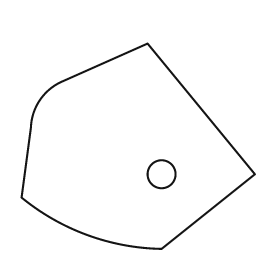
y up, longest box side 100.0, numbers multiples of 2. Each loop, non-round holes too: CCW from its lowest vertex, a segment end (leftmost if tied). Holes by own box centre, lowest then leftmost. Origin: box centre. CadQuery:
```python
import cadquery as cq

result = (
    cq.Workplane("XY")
    .moveTo(10.0, -44.0)
    .lineTo(50.0, -12.0)
    .lineTo(4.0, 44.0)
    .lineTo(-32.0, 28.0)
    .threePointArc((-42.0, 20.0), (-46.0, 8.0))
    .lineTo(-50.0, -22.0)
    .threePointArc((-22.0, -38.0), (10.0, -44.0))
    .close()
    .moveTo(10.0, -12.0)
    .circle(6.0)
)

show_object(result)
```